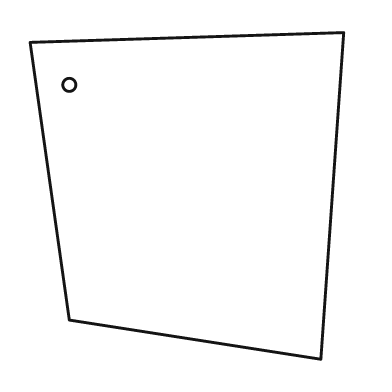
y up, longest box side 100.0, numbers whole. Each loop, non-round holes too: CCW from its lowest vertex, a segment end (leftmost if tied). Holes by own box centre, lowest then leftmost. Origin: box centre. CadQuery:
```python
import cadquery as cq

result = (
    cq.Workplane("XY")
    .moveTo(41.0, -50.0)
    .lineTo(48.0, 50.0)
    .lineTo(-48.0, 47.0)
    .lineTo(-36.0, -38.0)
    .close()
    .moveTo(-36.0, 34.0)
    .circle(2.0)
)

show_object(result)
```